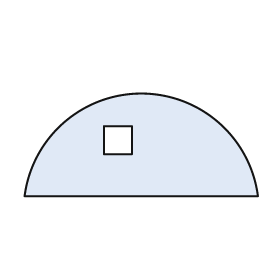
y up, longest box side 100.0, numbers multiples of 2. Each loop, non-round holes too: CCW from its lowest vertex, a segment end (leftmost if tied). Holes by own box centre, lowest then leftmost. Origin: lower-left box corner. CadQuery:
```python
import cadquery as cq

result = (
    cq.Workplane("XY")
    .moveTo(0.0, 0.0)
    .lineTo(100.0, 0.0)
    .threePointArc((50.0, 44.0), (0.0, 0.0))
    .close()
    .moveTo(34.0, 18.0)
    .lineTo(46.0, 18.0)
    .lineTo(46.0, 30.0)
    .lineTo(34.0, 30.0)
    .close()
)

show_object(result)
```